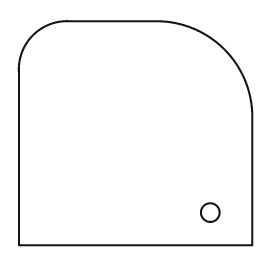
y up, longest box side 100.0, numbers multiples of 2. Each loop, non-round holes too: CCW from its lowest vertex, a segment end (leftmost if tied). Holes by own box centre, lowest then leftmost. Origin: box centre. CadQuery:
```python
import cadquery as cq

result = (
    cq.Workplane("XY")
    .moveTo(-50.0, -48.0)
    .lineTo(50.0, -48.0)
    .lineTo(50.0, 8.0)
    .threePointArc((38.0, 36.0), (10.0, 48.0))
    .lineTo(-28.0, 48.0)
    .threePointArc((-44.0, 42.0), (-50.0, 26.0))
    .close()
    .moveTo(32.0, -34.0)
    .circle(4.0)
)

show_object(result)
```